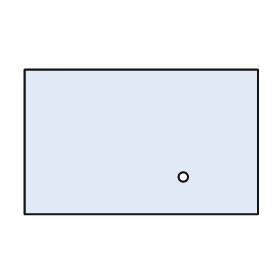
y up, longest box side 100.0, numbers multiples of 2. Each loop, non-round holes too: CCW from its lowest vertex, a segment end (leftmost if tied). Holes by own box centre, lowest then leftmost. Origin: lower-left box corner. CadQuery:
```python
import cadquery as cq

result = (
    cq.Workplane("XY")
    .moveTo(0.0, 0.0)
    .lineTo(100.0, 0.0)
    .lineTo(100.0, 62.0)
    .lineTo(0.0, 62.0)
    .close()
    .moveTo(68.0, 16.0)
    .circle(2.0)
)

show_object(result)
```